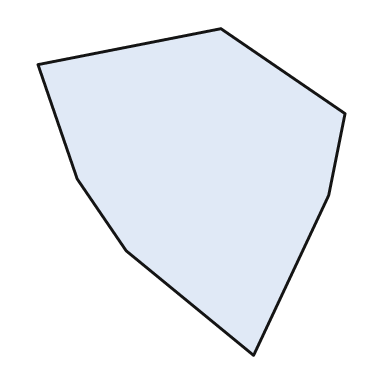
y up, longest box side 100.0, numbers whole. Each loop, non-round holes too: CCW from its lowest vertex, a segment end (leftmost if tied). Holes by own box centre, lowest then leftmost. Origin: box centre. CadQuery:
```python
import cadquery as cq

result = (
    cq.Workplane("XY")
    .moveTo(19.0, -50.0)
    .lineTo(42.0, -1.0)
    .lineTo(47.0, 24.0)
    .lineTo(9.0, 50.0)
    .lineTo(-47.0, 39.0)
    .lineTo(-35.0, 4.0)
    .lineTo(-20.0, -18.0)
    .close()
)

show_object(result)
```